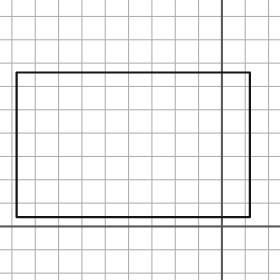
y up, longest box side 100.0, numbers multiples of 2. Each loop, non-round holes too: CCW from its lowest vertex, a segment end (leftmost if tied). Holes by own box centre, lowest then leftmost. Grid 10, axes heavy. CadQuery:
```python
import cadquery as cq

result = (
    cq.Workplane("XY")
    .moveTo(-88.0, 4.0)
    .lineTo(12.0, 4.0)
    .lineTo(12.0, 66.0)
    .lineTo(-88.0, 66.0)
    .close()
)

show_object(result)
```